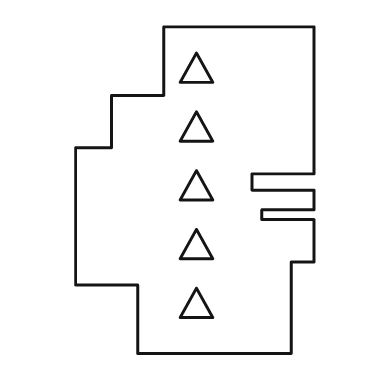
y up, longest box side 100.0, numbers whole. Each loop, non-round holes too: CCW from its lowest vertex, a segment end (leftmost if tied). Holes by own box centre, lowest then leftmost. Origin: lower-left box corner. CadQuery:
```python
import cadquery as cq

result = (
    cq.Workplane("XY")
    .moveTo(19.0, 0.0)
    .lineTo(66.0, 0.0)
    .lineTo(66.0, 28.0)
    .lineTo(73.0, 28.0)
    .lineTo(73.0, 41.0)
    .lineTo(57.0, 41.0)
    .lineTo(57.0, 44.0)
    .lineTo(73.0, 44.0)
    .lineTo(73.0, 50.0)
    .lineTo(54.0, 50.0)
    .lineTo(54.0, 55.0)
    .lineTo(73.0, 55.0)
    .lineTo(73.0, 100.0)
    .lineTo(27.0, 100.0)
    .lineTo(27.0, 79.0)
    .lineTo(11.0, 79.0)
    .lineTo(11.0, 63.0)
    .lineTo(0.0, 63.0)
    .lineTo(0.0, 21.0)
    .lineTo(19.0, 21.0)
    .close()
    .moveTo(32.0, 11.0)
    .lineTo(42.0, 11.0)
    .lineTo(37.0, 20.0)
    .close()
    .moveTo(32.0, 29.0)
    .lineTo(42.0, 29.0)
    .lineTo(37.0, 38.0)
    .close()
    .moveTo(32.0, 47.0)
    .lineTo(42.0, 47.0)
    .lineTo(37.0, 56.0)
    .close()
    .moveTo(32.0, 65.0)
    .lineTo(42.0, 65.0)
    .lineTo(37.0, 74.0)
    .close()
    .moveTo(32.0, 83.0)
    .lineTo(42.0, 83.0)
    .lineTo(37.0, 92.0)
    .close()
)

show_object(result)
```